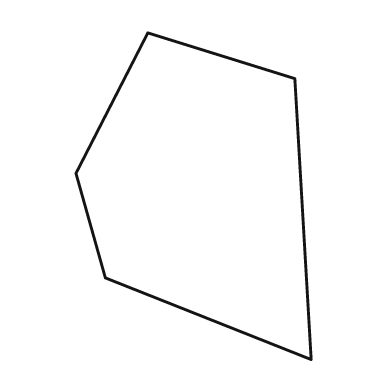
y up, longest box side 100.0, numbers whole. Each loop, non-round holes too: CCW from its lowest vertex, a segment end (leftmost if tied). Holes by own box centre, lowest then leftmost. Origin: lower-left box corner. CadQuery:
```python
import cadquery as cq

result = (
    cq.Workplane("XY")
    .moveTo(72.0, 0.0)
    .lineTo(67.0, 86.0)
    .lineTo(22.0, 100.0)
    .lineTo(0.0, 57.0)
    .lineTo(9.0, 25.0)
    .close()
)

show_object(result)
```